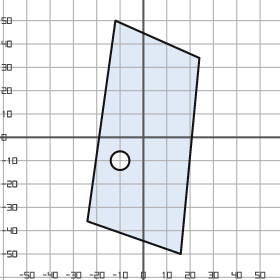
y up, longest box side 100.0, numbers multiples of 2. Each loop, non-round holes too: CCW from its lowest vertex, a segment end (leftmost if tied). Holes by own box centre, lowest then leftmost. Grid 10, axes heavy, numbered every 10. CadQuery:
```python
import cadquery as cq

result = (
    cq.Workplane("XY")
    .moveTo(16.0, -50.0)
    .lineTo(24.0, 34.0)
    .lineTo(-12.0, 50.0)
    .lineTo(-24.0, -36.0)
    .close()
    .moveTo(-10.0, -10.0)
    .circle(4.0)
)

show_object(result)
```